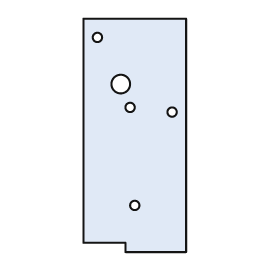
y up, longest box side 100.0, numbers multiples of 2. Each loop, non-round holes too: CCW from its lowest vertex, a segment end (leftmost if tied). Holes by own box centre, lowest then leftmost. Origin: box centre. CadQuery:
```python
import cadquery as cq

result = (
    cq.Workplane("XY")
    .moveTo(-4.0, -50.0)
    .lineTo(22.0, -50.0)
    .lineTo(22.0, 50.0)
    .lineTo(-22.0, 50.0)
    .lineTo(-22.0, -46.0)
    .lineTo(-4.0, -46.0)
    .close()
    .moveTo(0.0, -30.0)
    .circle(2.0)
    .moveTo(16.0, 10.0)
    .circle(2.0)
    .moveTo(-2.0, 12.0)
    .circle(2.0)
    .moveTo(-6.0, 22.0)
    .circle(4.0)
    .moveTo(-16.0, 42.0)
    .circle(2.0)
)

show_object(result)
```